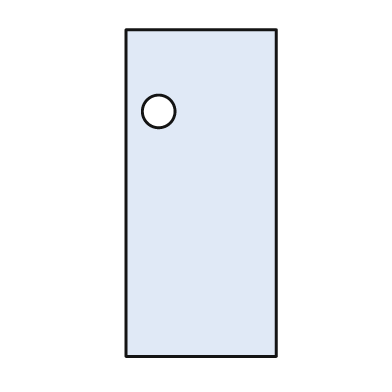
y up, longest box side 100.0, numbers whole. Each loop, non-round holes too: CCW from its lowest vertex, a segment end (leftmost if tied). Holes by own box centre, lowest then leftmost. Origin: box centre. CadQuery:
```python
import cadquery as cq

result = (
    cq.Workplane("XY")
    .moveTo(-23.0, -50.0)
    .lineTo(23.0, -50.0)
    .lineTo(23.0, 50.0)
    .lineTo(-23.0, 50.0)
    .close()
    .moveTo(-13.0, 25.0)
    .circle(5.0)
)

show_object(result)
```